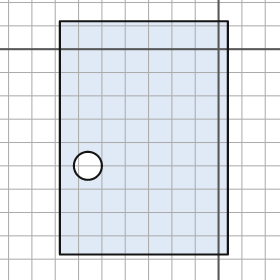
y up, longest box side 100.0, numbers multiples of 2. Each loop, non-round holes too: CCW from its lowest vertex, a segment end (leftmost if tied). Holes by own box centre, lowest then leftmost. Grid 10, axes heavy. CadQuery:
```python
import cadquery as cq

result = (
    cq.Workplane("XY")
    .moveTo(-68.0, -88.0)
    .lineTo(4.0, -88.0)
    .lineTo(4.0, 12.0)
    .lineTo(-68.0, 12.0)
    .close()
    .moveTo(-56.0, -50.0)
    .circle(6.0)
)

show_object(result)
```